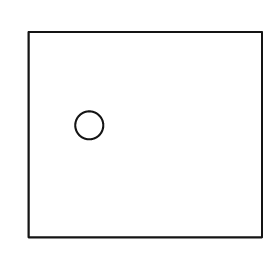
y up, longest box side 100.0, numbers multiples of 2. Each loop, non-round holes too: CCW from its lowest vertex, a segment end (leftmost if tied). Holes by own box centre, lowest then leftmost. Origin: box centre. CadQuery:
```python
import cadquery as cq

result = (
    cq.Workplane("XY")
    .moveTo(-50.0, -44.0)
    .lineTo(50.0, -44.0)
    .lineTo(50.0, 44.0)
    .lineTo(-50.0, 44.0)
    .close()
    .moveTo(-24.0, 4.0)
    .circle(6.0)
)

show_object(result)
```